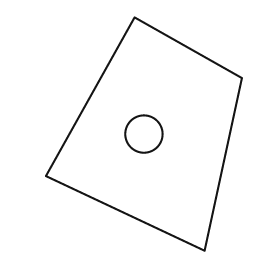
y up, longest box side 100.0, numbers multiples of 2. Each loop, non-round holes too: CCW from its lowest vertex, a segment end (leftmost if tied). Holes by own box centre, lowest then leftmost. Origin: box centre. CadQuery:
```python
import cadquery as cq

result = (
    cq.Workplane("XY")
    .moveTo(26.0, -50.0)
    .lineTo(42.0, 24.0)
    .lineTo(-4.0, 50.0)
    .lineTo(-42.0, -18.0)
    .close()
    .moveTo(0.0, 0.0)
    .circle(8.0)
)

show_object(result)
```